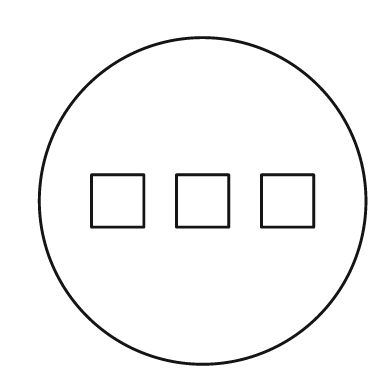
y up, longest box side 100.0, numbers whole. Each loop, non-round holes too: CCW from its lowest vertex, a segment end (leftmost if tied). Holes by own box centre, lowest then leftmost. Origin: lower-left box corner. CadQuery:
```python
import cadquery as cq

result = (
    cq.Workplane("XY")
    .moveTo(50.0, 50.0)
    .circle(50.0)
    .moveTo(16.0, 42.0)
    .lineTo(32.0, 42.0)
    .lineTo(32.0, 58.0)
    .lineTo(16.0, 58.0)
    .close()
    .moveTo(42.0, 42.0)
    .lineTo(58.0, 42.0)
    .lineTo(58.0, 58.0)
    .lineTo(42.0, 58.0)
    .close()
    .moveTo(68.0, 42.0)
    .lineTo(84.0, 42.0)
    .lineTo(84.0, 58.0)
    .lineTo(68.0, 58.0)
    .close()
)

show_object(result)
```